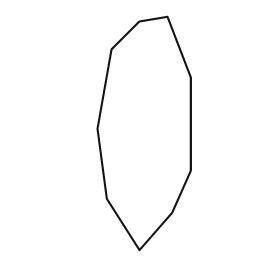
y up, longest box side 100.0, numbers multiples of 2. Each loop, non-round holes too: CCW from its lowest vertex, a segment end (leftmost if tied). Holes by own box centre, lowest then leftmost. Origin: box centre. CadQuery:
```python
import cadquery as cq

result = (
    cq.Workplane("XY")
    .moveTo(-2.0, -50.0)
    .lineTo(12.0, -34.0)
    .lineTo(20.0, -16.0)
    .lineTo(20.0, 24.0)
    .lineTo(10.0, 50.0)
    .lineTo(-2.0, 48.0)
    .lineTo(-14.0, 36.0)
    .lineTo(-20.0, 2.0)
    .lineTo(-16.0, -28.0)
    .close()
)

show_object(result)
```